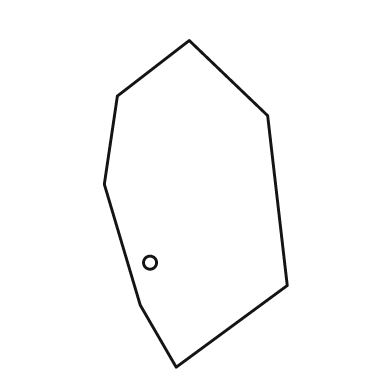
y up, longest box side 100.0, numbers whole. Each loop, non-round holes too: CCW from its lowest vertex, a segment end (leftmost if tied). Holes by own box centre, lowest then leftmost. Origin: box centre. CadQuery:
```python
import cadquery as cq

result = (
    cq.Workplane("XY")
    .moveTo(-6.0, -50.0)
    .lineTo(28.0, -25.0)
    .lineTo(22.0, 27.0)
    .lineTo(-2.0, 50.0)
    .lineTo(-24.0, 33.0)
    .lineTo(-28.0, 6.0)
    .lineTo(-17.0, -31.0)
    .close()
    .moveTo(-14.0, -18.0)
    .circle(2.0)
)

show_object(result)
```